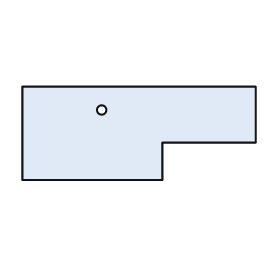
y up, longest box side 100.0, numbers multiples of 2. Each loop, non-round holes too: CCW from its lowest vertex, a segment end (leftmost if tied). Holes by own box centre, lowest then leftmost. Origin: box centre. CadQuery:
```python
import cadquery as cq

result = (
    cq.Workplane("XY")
    .moveTo(-50.0, -20.0)
    .lineTo(10.0, -20.0)
    .lineTo(10.0, -4.0)
    .lineTo(50.0, -4.0)
    .lineTo(50.0, 20.0)
    .lineTo(-50.0, 20.0)
    .close()
    .moveTo(-16.0, 10.0)
    .circle(2.0)
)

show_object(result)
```